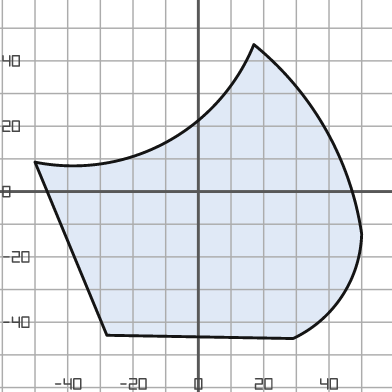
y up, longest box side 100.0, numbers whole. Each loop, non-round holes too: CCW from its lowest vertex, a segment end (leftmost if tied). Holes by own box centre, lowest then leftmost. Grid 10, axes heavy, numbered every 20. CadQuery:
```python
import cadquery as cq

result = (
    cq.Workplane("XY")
    .moveTo(29.0, -45.0)
    .threePointArc((44.0, -32.0), (50.0, -13.0))
    .threePointArc((39.0, 19.0), (17.0, 45.0))
    .threePointArc((-10.0, 15.0), (-50.0, 9.0))
    .lineTo(-28.0, -44.0)
    .close()
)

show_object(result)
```